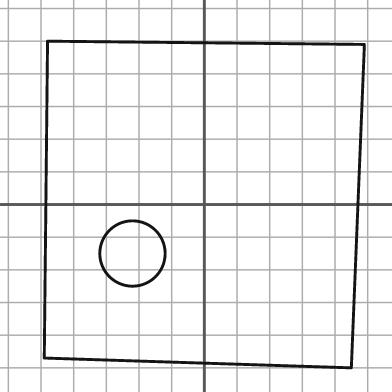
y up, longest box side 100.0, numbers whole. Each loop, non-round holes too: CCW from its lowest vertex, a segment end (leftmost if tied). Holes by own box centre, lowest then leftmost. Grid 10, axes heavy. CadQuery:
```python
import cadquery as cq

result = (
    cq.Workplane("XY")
    .moveTo(45.0, -50.0)
    .lineTo(49.0, 49.0)
    .lineTo(-48.0, 50.0)
    .lineTo(-49.0, -47.0)
    .close()
    .moveTo(-22.0, -15.0)
    .circle(10.0)
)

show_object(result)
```